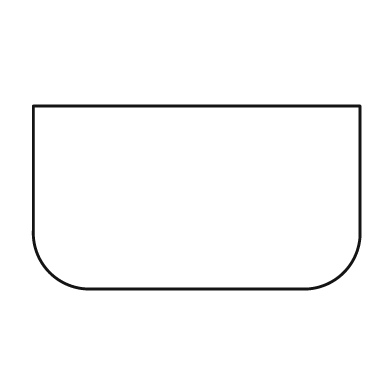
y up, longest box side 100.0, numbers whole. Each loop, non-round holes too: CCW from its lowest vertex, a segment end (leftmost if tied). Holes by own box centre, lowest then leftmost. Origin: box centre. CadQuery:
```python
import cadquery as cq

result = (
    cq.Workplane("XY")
    .moveTo(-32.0, -28.0)
    .lineTo(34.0, -28.0)
    .threePointArc((45.0, -23.0), (50.0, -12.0))
    .lineTo(50.0, 28.0)
    .lineTo(-50.0, 28.0)
    .lineTo(-50.0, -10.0)
    .threePointArc((-45.0, -23.0), (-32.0, -28.0))
    .close()
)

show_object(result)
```